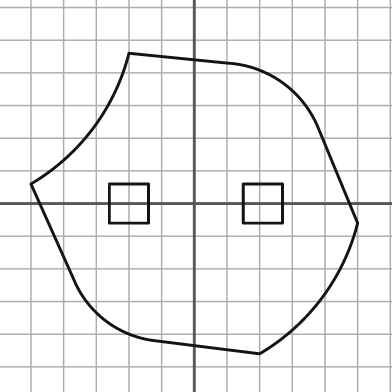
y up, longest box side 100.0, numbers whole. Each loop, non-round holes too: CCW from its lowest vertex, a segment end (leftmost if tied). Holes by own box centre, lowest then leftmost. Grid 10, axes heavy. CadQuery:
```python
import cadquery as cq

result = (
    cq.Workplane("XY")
    .moveTo(20.0, -46.0)
    .threePointArc((39.0, -29.0), (50.0, -6.0))
    .lineTo(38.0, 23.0)
    .threePointArc((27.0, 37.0), (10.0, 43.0))
    .lineTo(-20.0, 46.0)
    .threePointArc((-31.0, 23.0), (-50.0, 6.0))
    .lineTo(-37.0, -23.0)
    .threePointArc((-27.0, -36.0), (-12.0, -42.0))
    .close()
    .moveTo(-26.0, -6.0)
    .lineTo(-14.0, -6.0)
    .lineTo(-14.0, 6.0)
    .lineTo(-26.0, 6.0)
    .close()
    .moveTo(15.0, -6.0)
    .lineTo(27.0, -6.0)
    .lineTo(27.0, 6.0)
    .lineTo(15.0, 6.0)
    .close()
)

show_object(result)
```